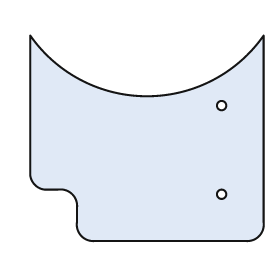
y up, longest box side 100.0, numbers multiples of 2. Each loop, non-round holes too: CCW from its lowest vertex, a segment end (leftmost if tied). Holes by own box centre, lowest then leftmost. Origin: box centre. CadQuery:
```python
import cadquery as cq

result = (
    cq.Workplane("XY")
    .moveTo(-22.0, -44.0)
    .lineTo(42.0, -44.0)
    .threePointArc((48.0, -42.0), (50.0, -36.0))
    .lineTo(50.0, 44.0)
    .threePointArc((0.0, 18.0), (-50.0, 44.0))
    .lineTo(-50.0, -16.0)
    .threePointArc((-48.0, -20.0), (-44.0, -22.0))
    .lineTo(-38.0, -22.0)
    .threePointArc((-32.0, -24.0), (-30.0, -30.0))
    .lineTo(-30.0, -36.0)
    .threePointArc((-28.0, -42.0), (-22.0, -44.0))
    .close()
    .moveTo(32.0, -24.0)
    .circle(2.0)
    .moveTo(32.0, 14.0)
    .circle(2.0)
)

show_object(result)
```